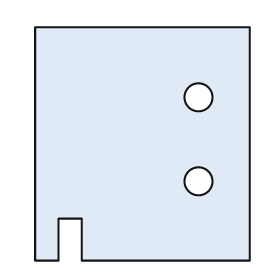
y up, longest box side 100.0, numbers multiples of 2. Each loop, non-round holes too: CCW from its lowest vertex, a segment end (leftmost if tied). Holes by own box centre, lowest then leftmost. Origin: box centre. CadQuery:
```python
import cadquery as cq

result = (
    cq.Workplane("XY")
    .moveTo(-46.0, -50.0)
    .lineTo(-36.0, -50.0)
    .lineTo(-36.0, -32.0)
    .lineTo(-26.0, -32.0)
    .lineTo(-26.0, -50.0)
    .lineTo(46.0, -50.0)
    .lineTo(46.0, 50.0)
    .lineTo(-46.0, 50.0)
    .close()
    .moveTo(24.0, -16.0)
    .circle(6.0)
    .moveTo(24.0, 20.0)
    .circle(6.0)
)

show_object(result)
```